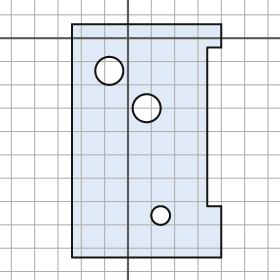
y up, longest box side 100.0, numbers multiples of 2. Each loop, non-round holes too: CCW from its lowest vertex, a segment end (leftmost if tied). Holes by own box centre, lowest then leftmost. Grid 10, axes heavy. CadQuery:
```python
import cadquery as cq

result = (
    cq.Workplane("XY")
    .moveTo(-24.0, -94.0)
    .lineTo(40.0, -94.0)
    .lineTo(40.0, -72.0)
    .lineTo(34.0, -72.0)
    .lineTo(34.0, -4.0)
    .lineTo(40.0, -4.0)
    .lineTo(40.0, 6.0)
    .lineTo(-24.0, 6.0)
    .close()
    .moveTo(14.0, -76.0)
    .circle(4.0)
    .moveTo(8.0, -30.0)
    .circle(6.0)
    .moveTo(-8.0, -14.0)
    .circle(6.0)
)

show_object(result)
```